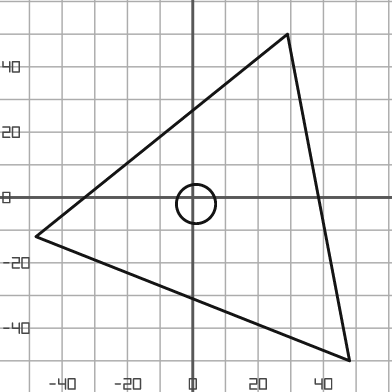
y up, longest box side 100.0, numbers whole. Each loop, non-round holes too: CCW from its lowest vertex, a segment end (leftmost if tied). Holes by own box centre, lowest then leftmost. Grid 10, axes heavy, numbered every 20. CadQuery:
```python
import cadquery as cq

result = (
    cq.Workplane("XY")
    .moveTo(48.0, -50.0)
    .lineTo(29.0, 50.0)
    .lineTo(-48.0, -12.0)
    .close()
    .moveTo(1.0, -2.0)
    .circle(6.0)
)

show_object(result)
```